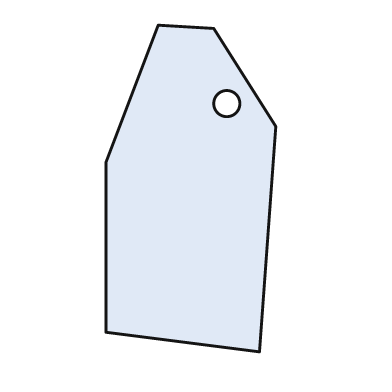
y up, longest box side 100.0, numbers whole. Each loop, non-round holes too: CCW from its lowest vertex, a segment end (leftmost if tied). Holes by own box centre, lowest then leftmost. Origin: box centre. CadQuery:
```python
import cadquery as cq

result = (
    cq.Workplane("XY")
    .moveTo(21.0, -50.0)
    .lineTo(26.0, 19.0)
    .lineTo(7.0, 49.0)
    .lineTo(-10.0, 50.0)
    .lineTo(-26.0, 8.0)
    .lineTo(-26.0, -44.0)
    .close()
    .moveTo(11.0, 26.0)
    .circle(4.0)
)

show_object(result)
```